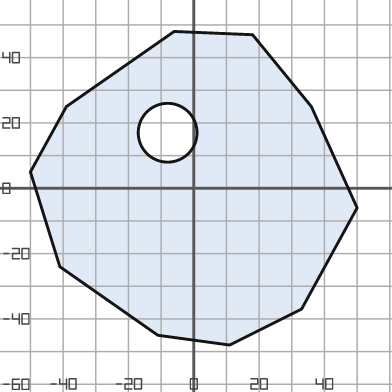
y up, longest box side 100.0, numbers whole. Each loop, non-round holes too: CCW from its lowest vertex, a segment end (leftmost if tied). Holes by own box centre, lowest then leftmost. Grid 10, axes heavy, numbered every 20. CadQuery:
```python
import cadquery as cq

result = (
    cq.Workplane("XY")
    .moveTo(11.0, -48.0)
    .lineTo(33.0, -37.0)
    .lineTo(50.0, -6.0)
    .lineTo(36.0, 25.0)
    .lineTo(18.0, 47.0)
    .lineTo(-6.0, 48.0)
    .lineTo(-39.0, 25.0)
    .lineTo(-50.0, 5.0)
    .lineTo(-41.0, -24.0)
    .lineTo(-11.0, -45.0)
    .close()
    .moveTo(-8.0, 17.0)
    .circle(9.0)
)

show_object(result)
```